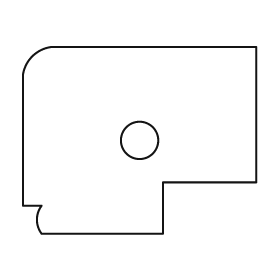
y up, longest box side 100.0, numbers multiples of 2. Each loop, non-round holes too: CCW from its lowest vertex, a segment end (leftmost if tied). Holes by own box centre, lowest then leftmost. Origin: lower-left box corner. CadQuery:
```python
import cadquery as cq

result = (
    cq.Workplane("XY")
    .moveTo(8.0, 0.0)
    .lineTo(60.0, 0.0)
    .lineTo(60.0, 22.0)
    .lineTo(100.0, 22.0)
    .lineTo(100.0, 80.0)
    .lineTo(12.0, 80.0)
    .threePointArc((4.0, 76.0), (0.0, 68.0))
    .lineTo(0.0, 12.0)
    .lineTo(8.0, 12.0)
    .threePointArc((6.0, 6.0), (8.0, 0.0))
    .close()
    .moveTo(50.0, 40.0)
    .circle(8.0)
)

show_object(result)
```